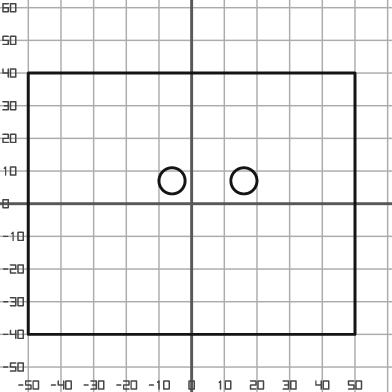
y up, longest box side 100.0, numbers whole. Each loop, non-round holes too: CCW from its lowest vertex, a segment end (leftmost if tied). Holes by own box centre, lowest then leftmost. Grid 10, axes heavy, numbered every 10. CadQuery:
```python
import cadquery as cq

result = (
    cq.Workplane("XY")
    .moveTo(-50.0, -40.0)
    .lineTo(50.0, -40.0)
    .lineTo(50.0, 40.0)
    .lineTo(-50.0, 40.0)
    .close()
    .moveTo(-6.0, 7.0)
    .circle(4.0)
    .moveTo(16.0, 7.0)
    .circle(4.0)
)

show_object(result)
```